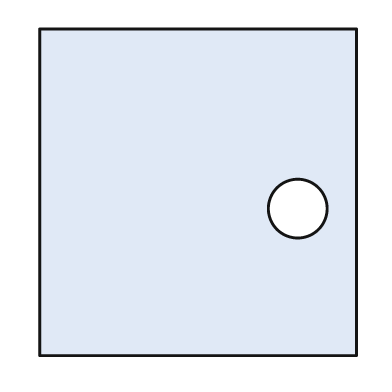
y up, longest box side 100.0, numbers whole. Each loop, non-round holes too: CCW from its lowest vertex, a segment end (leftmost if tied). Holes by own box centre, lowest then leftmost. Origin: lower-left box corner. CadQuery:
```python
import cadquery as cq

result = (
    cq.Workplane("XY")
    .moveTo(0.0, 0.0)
    .lineTo(97.0, 0.0)
    .lineTo(97.0, 100.0)
    .lineTo(0.0, 100.0)
    .close()
    .moveTo(79.0, 45.0)
    .circle(9.0)
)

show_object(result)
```